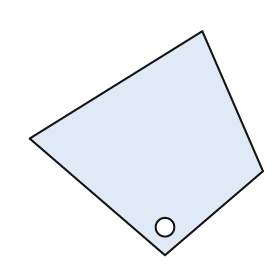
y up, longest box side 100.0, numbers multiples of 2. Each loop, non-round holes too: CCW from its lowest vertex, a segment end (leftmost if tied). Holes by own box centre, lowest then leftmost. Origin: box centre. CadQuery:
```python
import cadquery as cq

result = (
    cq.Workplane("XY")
    .moveTo(8.0, -48.0)
    .lineTo(50.0, -12.0)
    .lineTo(24.0, 48.0)
    .lineTo(-50.0, 2.0)
    .close()
    .moveTo(8.0, -36.0)
    .circle(4.0)
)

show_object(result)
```